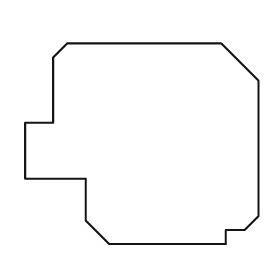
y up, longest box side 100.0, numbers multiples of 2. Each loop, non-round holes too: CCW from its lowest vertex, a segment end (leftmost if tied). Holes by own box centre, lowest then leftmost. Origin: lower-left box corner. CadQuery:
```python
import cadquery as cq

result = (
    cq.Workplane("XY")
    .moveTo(36.0, 0.0)
    .lineTo(86.0, 0.0)
    .lineTo(86.0, 6.0)
    .lineTo(94.0, 6.0)
    .lineTo(100.0, 12.0)
    .lineTo(100.0, 70.0)
    .lineTo(84.0, 86.0)
    .lineTo(18.0, 86.0)
    .lineTo(12.0, 80.0)
    .lineTo(12.0, 52.0)
    .lineTo(0.0, 52.0)
    .lineTo(0.0, 28.0)
    .lineTo(26.0, 28.0)
    .lineTo(26.0, 10.0)
    .close()
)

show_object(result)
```